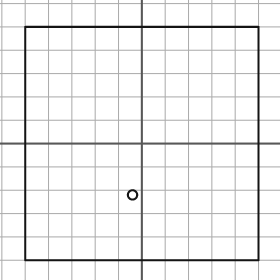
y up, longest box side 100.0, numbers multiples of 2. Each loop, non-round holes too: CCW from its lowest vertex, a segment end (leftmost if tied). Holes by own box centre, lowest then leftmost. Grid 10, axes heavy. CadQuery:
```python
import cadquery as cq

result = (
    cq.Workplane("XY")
    .moveTo(-50.0, -50.0)
    .lineTo(50.0, -50.0)
    .lineTo(50.0, 50.0)
    .lineTo(-50.0, 50.0)
    .close()
    .moveTo(-4.0, -22.0)
    .circle(2.0)
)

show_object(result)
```